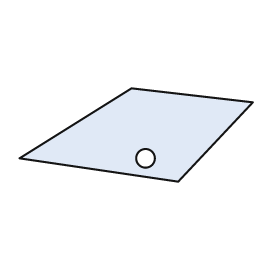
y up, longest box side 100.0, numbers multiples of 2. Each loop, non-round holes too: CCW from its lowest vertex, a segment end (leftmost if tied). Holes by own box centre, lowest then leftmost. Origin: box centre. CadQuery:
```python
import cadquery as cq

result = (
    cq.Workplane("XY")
    .moveTo(18.0, -20.0)
    .lineTo(50.0, 14.0)
    .lineTo(-2.0, 20.0)
    .lineTo(-50.0, -10.0)
    .close()
    .moveTo(4.0, -10.0)
    .circle(4.0)
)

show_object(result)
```